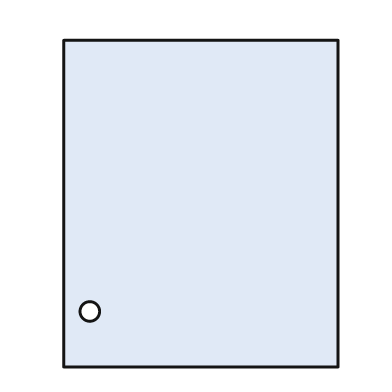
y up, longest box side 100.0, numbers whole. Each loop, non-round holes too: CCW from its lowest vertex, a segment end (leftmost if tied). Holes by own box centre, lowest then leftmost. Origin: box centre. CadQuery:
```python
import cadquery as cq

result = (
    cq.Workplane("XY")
    .moveTo(-42.0, -50.0)
    .lineTo(42.0, -50.0)
    .lineTo(42.0, 50.0)
    .lineTo(-42.0, 50.0)
    .close()
    .moveTo(-34.0, -33.0)
    .circle(3.0)
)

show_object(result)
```